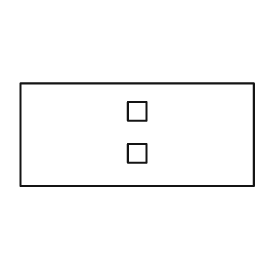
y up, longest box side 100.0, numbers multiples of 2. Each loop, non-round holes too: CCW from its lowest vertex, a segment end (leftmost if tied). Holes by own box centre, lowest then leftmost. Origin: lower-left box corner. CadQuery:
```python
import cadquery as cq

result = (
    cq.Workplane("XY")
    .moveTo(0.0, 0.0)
    .lineTo(100.0, 0.0)
    .lineTo(100.0, 44.0)
    .lineTo(0.0, 44.0)
    .close()
    .moveTo(46.0, 10.0)
    .lineTo(54.0, 10.0)
    .lineTo(54.0, 18.0)
    .lineTo(46.0, 18.0)
    .close()
    .moveTo(46.0, 28.0)
    .lineTo(54.0, 28.0)
    .lineTo(54.0, 36.0)
    .lineTo(46.0, 36.0)
    .close()
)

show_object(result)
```